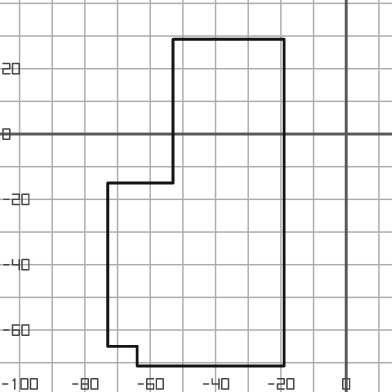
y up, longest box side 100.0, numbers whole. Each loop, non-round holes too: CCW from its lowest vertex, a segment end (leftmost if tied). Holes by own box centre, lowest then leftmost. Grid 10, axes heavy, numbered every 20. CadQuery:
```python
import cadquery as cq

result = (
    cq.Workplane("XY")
    .moveTo(-64.0, -71.0)
    .lineTo(-19.0, -71.0)
    .lineTo(-19.0, 29.0)
    .lineTo(-53.0, 29.0)
    .lineTo(-53.0, -15.0)
    .lineTo(-73.0, -15.0)
    .lineTo(-73.0, -65.0)
    .lineTo(-64.0, -65.0)
    .close()
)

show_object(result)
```